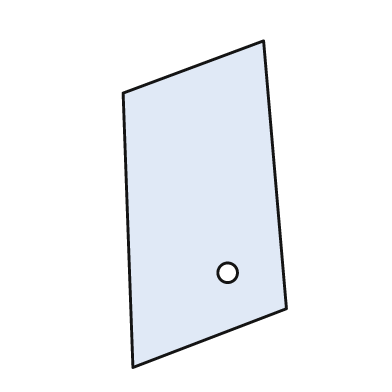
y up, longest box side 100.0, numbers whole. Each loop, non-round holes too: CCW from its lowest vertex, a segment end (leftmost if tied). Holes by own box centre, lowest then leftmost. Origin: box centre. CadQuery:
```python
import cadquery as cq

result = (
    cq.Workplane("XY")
    .moveTo(-22.0, -50.0)
    .lineTo(25.0, -32.0)
    .lineTo(18.0, 50.0)
    .lineTo(-25.0, 34.0)
    .close()
    .moveTo(7.0, -21.0)
    .circle(3.0)
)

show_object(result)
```